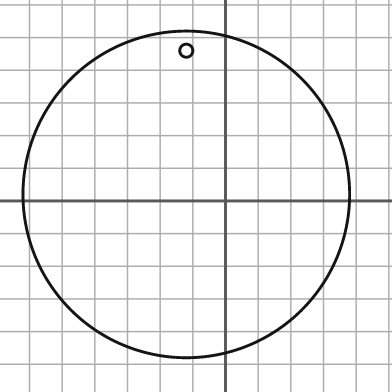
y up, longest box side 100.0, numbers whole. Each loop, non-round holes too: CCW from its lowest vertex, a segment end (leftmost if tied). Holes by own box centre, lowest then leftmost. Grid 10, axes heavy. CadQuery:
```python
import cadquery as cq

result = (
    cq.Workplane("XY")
    .moveTo(-12.0, 2.0)
    .circle(50.0)
    .moveTo(-12.0, 46.0)
    .circle(2.0)
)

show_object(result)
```